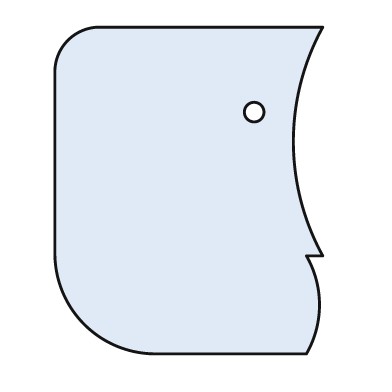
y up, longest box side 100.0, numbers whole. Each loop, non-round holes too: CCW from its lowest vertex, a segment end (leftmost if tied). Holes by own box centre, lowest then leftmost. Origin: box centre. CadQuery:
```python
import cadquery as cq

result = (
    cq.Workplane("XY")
    .moveTo(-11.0, -50.0)
    .lineTo(36.0, -50.0)
    .threePointArc((40.0, -35.0), (36.0, -20.0))
    .lineTo(41.0, -20.0)
    .threePointArc((32.0, 15.0), (41.0, 50.0))
    .lineTo(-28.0, 50.0)
    .threePointArc((-37.0, 46.0), (-41.0, 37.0))
    .lineTo(-41.0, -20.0)
    .threePointArc((-32.0, -41.0), (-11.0, -50.0))
    .close()
    .moveTo(20.0, 24.0)
    .circle(3.0)
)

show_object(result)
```